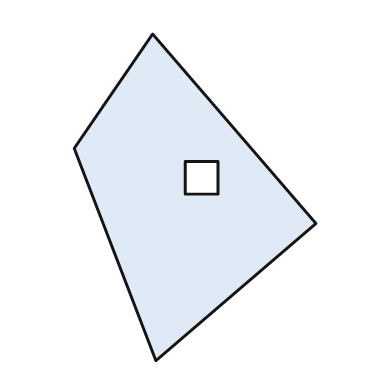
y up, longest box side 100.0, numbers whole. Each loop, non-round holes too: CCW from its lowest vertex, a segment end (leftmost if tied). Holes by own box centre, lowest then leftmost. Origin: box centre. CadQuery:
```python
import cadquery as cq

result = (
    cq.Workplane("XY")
    .moveTo(-12.0, -50.0)
    .lineTo(37.0, -8.0)
    .lineTo(-13.0, 50.0)
    .lineTo(-37.0, 15.0)
    .close()
    .moveTo(-3.0, 1.0)
    .lineTo(7.0, 1.0)
    .lineTo(7.0, 11.0)
    .lineTo(-3.0, 11.0)
    .close()
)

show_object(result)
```